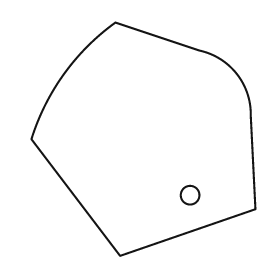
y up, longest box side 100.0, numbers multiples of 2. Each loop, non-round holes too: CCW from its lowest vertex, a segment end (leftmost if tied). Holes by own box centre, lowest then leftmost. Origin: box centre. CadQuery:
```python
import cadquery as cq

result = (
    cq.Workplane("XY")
    .moveTo(-10.0, -50.0)
    .lineTo(48.0, -30.0)
    .lineTo(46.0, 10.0)
    .threePointArc((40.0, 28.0), (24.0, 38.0))
    .lineTo(-12.0, 50.0)
    .threePointArc((-34.0, 28.0), (-48.0, 0.0))
    .close()
    .moveTo(20.0, -24.0)
    .circle(4.0)
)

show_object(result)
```